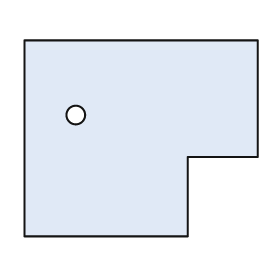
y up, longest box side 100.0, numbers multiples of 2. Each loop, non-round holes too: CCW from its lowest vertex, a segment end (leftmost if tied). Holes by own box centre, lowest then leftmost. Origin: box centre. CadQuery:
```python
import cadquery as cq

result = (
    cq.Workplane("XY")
    .moveTo(-50.0, -42.0)
    .lineTo(20.0, -42.0)
    .lineTo(20.0, -8.0)
    .lineTo(50.0, -8.0)
    .lineTo(50.0, 42.0)
    .lineTo(-50.0, 42.0)
    .close()
    .moveTo(-28.0, 10.0)
    .circle(4.0)
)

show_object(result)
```